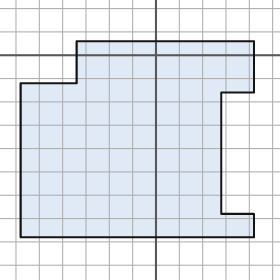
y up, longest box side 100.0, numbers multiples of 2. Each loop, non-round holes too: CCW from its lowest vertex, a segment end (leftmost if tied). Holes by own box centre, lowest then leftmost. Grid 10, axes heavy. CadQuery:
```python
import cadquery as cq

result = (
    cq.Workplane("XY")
    .moveTo(-58.0, -78.0)
    .lineTo(42.0, -78.0)
    .lineTo(42.0, -68.0)
    .lineTo(28.0, -68.0)
    .lineTo(28.0, -16.0)
    .lineTo(42.0, -16.0)
    .lineTo(42.0, 6.0)
    .lineTo(-34.0, 6.0)
    .lineTo(-34.0, -12.0)
    .lineTo(-58.0, -12.0)
    .close()
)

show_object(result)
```